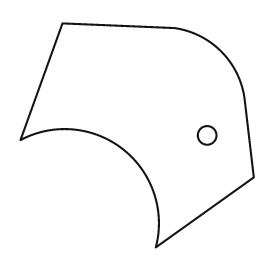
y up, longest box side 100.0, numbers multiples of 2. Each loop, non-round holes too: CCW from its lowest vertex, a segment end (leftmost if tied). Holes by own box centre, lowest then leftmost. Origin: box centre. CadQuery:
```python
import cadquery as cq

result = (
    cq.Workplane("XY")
    .moveTo(8.0, -48.0)
    .lineTo(50.0, -18.0)
    .lineTo(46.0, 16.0)
    .threePointArc((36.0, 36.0), (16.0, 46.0))
    .lineTo(-32.0, 48.0)
    .lineTo(-50.0, -2.0)
    .threePointArc((-6.0, -6.0), (8.0, -48.0))
    .close()
    .moveTo(30.0, 0.0)
    .circle(4.0)
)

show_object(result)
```